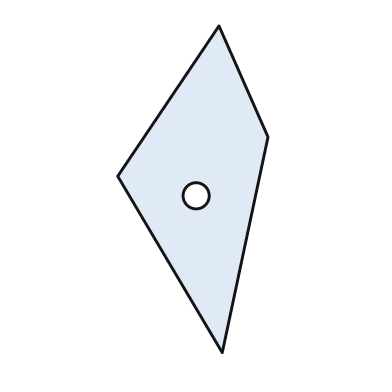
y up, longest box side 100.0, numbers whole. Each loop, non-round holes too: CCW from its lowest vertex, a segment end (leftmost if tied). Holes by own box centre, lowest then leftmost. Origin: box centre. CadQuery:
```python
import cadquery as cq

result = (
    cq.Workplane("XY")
    .moveTo(9.0, -50.0)
    .lineTo(23.0, 16.0)
    .lineTo(8.0, 50.0)
    .lineTo(-23.0, 4.0)
    .close()
    .moveTo(1.0, -2.0)
    .circle(4.0)
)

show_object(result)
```